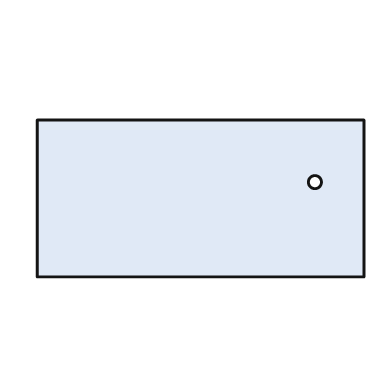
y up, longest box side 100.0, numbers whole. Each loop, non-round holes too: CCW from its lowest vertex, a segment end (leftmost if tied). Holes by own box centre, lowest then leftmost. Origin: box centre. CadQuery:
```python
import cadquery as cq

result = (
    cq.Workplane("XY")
    .moveTo(-50.0, -24.0)
    .lineTo(50.0, -24.0)
    .lineTo(50.0, 24.0)
    .lineTo(-50.0, 24.0)
    .close()
    .moveTo(35.0, 5.0)
    .circle(2.0)
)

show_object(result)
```